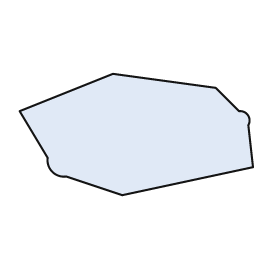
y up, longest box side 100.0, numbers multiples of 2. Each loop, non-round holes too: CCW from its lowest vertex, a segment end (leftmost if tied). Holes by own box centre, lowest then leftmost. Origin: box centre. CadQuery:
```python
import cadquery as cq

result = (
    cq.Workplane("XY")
    .moveTo(-6.0, -26.0)
    .lineTo(50.0, -14.0)
    .lineTo(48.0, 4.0)
    .threePointArc((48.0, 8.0), (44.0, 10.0))
    .lineTo(34.0, 20.0)
    .lineTo(-10.0, 26.0)
    .lineTo(-50.0, 10.0)
    .lineTo(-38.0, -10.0)
    .threePointArc((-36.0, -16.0), (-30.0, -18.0))
    .close()
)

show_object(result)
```